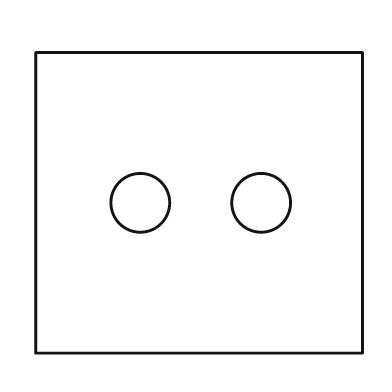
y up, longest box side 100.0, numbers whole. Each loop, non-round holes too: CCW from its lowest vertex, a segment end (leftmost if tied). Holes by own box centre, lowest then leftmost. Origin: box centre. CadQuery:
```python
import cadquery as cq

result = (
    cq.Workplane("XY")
    .moveTo(-50.0, -46.0)
    .lineTo(50.0, -46.0)
    .lineTo(50.0, 46.0)
    .lineTo(-50.0, 46.0)
    .close()
    .moveTo(-18.0, 0.0)
    .circle(9.0)
    .moveTo(19.0, 0.0)
    .circle(9.0)
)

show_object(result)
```